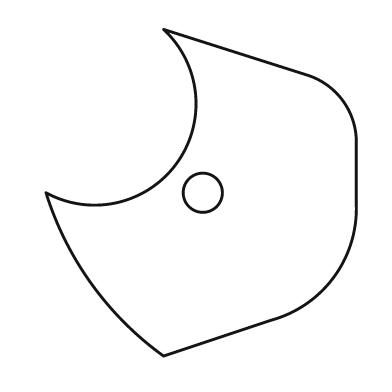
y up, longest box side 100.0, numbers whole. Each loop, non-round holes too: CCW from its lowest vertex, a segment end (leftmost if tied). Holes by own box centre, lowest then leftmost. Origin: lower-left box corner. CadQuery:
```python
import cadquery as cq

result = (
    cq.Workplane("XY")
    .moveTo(36.0, 0.0)
    .lineTo(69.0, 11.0)
    .threePointArc((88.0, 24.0), (95.0, 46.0))
    .lineTo(95.0, 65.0)
    .threePointArc((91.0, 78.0), (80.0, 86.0))
    .lineTo(36.0, 100.0)
    .threePointArc((40.0, 59.0), (0.0, 50.0))
    .threePointArc((14.0, 22.0), (36.0, 0.0))
    .close()
    .moveTo(48.0, 50.0)
    .circle(6.0)
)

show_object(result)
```